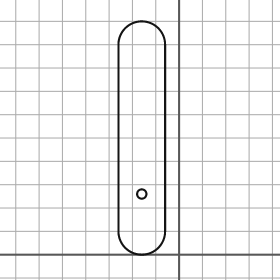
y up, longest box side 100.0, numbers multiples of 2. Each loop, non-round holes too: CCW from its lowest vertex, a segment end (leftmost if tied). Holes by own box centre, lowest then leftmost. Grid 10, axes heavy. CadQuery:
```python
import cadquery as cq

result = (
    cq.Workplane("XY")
    .moveTo(-26.0, 10.0)
    .threePointArc((-16.0, 0.0), (-6.0, 10.0))
    .lineTo(-6.0, 90.0)
    .threePointArc((-16.0, 100.0), (-26.0, 90.0))
    .close()
    .moveTo(-16.0, 26.0)
    .circle(2.0)
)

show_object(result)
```